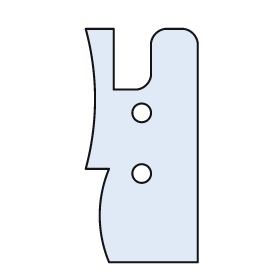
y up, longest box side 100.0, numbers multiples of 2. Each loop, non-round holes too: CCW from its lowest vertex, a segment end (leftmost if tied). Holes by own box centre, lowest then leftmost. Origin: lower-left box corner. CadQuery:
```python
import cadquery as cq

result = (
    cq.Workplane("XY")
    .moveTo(10.0, 0.0)
    .lineTo(48.0, 0.0)
    .lineTo(48.0, 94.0)
    .threePointArc((46.0, 98.0), (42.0, 100.0))
    .lineTo(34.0, 100.0)
    .threePointArc((30.0, 98.0), (28.0, 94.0))
    .lineTo(28.0, 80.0)
    .threePointArc((26.0, 76.0), (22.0, 74.0))
    .lineTo(12.0, 74.0)
    .lineTo(12.0, 100.0)
    .lineTo(0.0, 100.0)
    .threePointArc((4.0, 70.0), (0.0, 40.0))
    .lineTo(10.0, 40.0)
    .threePointArc((6.0, 20.0), (10.0, 0.0))
    .close()
    .moveTo(24.0, 38.0)
    .circle(4.0)
    .moveTo(24.0, 64.0)
    .circle(4.0)
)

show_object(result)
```